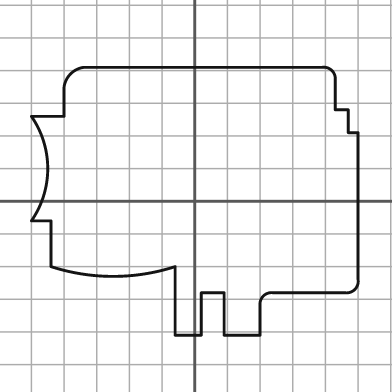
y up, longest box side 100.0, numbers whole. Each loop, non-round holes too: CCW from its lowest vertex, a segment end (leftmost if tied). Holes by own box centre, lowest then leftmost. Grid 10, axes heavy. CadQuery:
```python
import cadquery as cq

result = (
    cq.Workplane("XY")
    .moveTo(-6.0, -41.0)
    .lineTo(2.0, -41.0)
    .lineTo(2.0, -28.0)
    .lineTo(9.0, -28.0)
    .lineTo(9.0, -41.0)
    .lineTo(20.0, -41.0)
    .lineTo(20.0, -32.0)
    .threePointArc((21.0, -29.0), (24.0, -28.0))
    .lineTo(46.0, -28.0)
    .threePointArc((49.0, -27.0), (50.0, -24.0))
    .lineTo(50.0, 21.0)
    .lineTo(47.0, 21.0)
    .lineTo(47.0, 28.0)
    .lineTo(43.0, 28.0)
    .lineTo(43.0, 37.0)
    .threePointArc((42.0, 40.0), (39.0, 41.0))
    .lineTo(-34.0, 41.0)
    .threePointArc((-38.0, 39.0), (-40.0, 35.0))
    .lineTo(-40.0, 26.0)
    .lineTo(-50.0, 26.0)
    .threePointArc((-45.0, 10.0), (-50.0, -6.0))
    .lineTo(-44.0, -6.0)
    .lineTo(-44.0, -20.0)
    .threePointArc((-25.0, -23.0), (-6.0, -20.0))
    .close()
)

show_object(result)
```